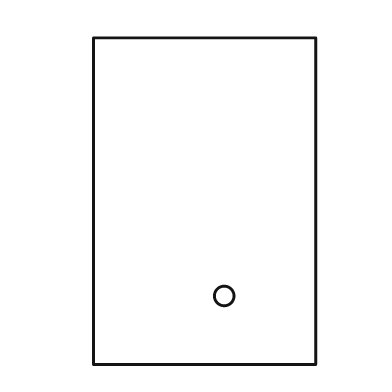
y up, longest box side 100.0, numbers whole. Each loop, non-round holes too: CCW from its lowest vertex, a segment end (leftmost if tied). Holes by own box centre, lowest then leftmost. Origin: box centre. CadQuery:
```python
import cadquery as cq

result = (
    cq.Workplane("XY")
    .moveTo(-34.0, -50.0)
    .lineTo(34.0, -50.0)
    .lineTo(34.0, 50.0)
    .lineTo(-34.0, 50.0)
    .close()
    .moveTo(6.0, -29.0)
    .circle(3.0)
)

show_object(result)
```